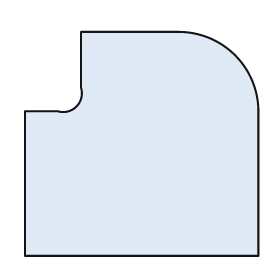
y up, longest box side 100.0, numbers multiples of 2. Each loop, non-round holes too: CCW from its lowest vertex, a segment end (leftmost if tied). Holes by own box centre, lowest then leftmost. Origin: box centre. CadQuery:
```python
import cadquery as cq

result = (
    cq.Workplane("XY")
    .moveTo(-50.0, -48.0)
    .lineTo(50.0, -48.0)
    .lineTo(50.0, 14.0)
    .threePointArc((40.0, 38.0), (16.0, 48.0))
    .lineTo(-26.0, 48.0)
    .lineTo(-26.0, 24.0)
    .threePointArc((-28.0, 16.0), (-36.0, 14.0))
    .lineTo(-50.0, 14.0)
    .close()
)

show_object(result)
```